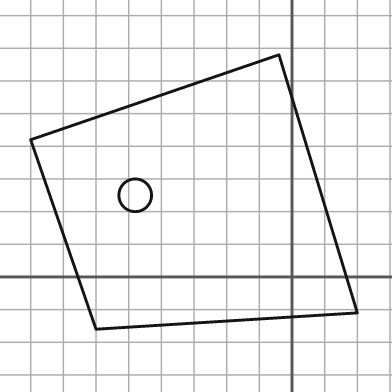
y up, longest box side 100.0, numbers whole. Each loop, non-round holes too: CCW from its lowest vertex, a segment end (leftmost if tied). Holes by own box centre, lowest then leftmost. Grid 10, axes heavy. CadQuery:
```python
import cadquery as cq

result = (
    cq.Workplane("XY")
    .moveTo(-60.0, -16.0)
    .lineTo(20.0, -11.0)
    .lineTo(-4.0, 68.0)
    .lineTo(-80.0, 42.0)
    .close()
    .moveTo(-48.0, 25.0)
    .circle(5.0)
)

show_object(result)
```